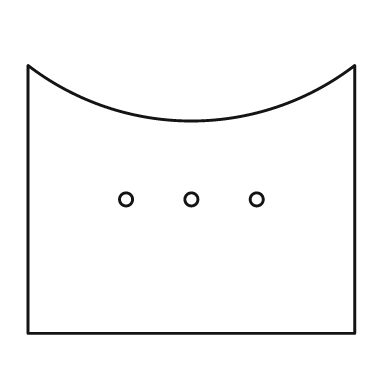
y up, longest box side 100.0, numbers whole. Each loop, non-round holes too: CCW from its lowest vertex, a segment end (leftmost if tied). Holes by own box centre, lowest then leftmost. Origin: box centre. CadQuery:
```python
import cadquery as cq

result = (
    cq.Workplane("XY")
    .moveTo(-50.0, -41.0)
    .lineTo(50.0, -41.0)
    .lineTo(50.0, 41.0)
    .threePointArc((0.0, 24.0), (-50.0, 41.0))
    .close()
    .moveTo(-20.0, 0.0)
    .circle(2.0)
    .moveTo(0.0, 0.0)
    .circle(2.0)
    .moveTo(20.0, 0.0)
    .circle(2.0)
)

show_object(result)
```